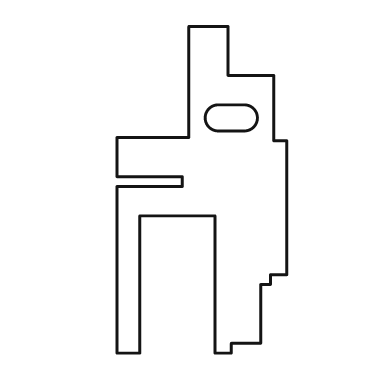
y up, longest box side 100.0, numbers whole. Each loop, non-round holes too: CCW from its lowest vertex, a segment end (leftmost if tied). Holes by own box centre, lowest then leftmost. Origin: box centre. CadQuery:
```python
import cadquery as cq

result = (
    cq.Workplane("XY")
    .moveTo(-26.0, -50.0)
    .lineTo(-19.0, -50.0)
    .lineTo(-19.0, -8.0)
    .lineTo(4.0, -8.0)
    .lineTo(4.0, -50.0)
    .lineTo(9.0, -50.0)
    .lineTo(9.0, -47.0)
    .lineTo(18.0, -47.0)
    .lineTo(18.0, -29.0)
    .lineTo(21.0, -29.0)
    .lineTo(21.0, -26.0)
    .lineTo(26.0, -26.0)
    .lineTo(26.0, 15.0)
    .lineTo(22.0, 15.0)
    .lineTo(22.0, 35.0)
    .lineTo(8.0, 35.0)
    .lineTo(8.0, 50.0)
    .lineTo(-4.0, 50.0)
    .lineTo(-4.0, 16.0)
    .lineTo(-26.0, 16.0)
    .lineTo(-26.0, 4.0)
    .lineTo(-6.0, 4.0)
    .lineTo(-6.0, 1.0)
    .lineTo(-26.0, 1.0)
    .close()
    .moveTo(5.0, 18.0)
    .lineTo(13.0, 18.0)
    .threePointArc((17.0, 22.0), (13.0, 26.0))
    .lineTo(5.0, 26.0)
    .threePointArc((1.0, 22.0), (5.0, 18.0))
    .close()
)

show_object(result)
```